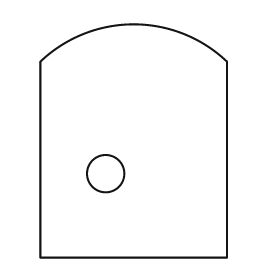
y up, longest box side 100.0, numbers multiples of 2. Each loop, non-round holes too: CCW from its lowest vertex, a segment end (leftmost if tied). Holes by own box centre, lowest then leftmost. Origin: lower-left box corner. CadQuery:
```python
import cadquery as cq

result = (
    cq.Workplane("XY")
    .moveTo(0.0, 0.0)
    .lineTo(80.0, 0.0)
    .lineTo(80.0, 84.0)
    .threePointArc((40.0, 100.0), (0.0, 84.0))
    .close()
    .moveTo(28.0, 36.0)
    .circle(8.0)
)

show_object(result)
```